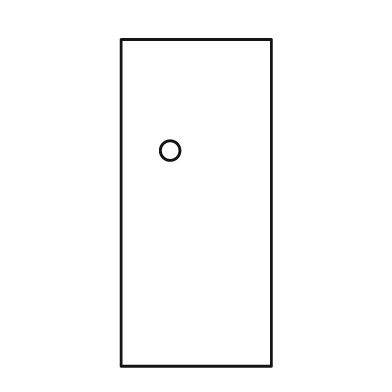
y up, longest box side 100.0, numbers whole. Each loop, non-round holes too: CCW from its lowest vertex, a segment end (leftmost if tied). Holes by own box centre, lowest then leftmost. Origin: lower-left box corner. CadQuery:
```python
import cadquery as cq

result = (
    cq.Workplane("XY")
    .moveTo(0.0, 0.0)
    .lineTo(46.0, 0.0)
    .lineTo(46.0, 100.0)
    .lineTo(0.0, 100.0)
    .close()
    .moveTo(15.0, 66.0)
    .circle(3.0)
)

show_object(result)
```